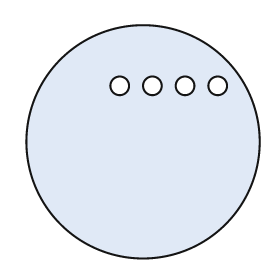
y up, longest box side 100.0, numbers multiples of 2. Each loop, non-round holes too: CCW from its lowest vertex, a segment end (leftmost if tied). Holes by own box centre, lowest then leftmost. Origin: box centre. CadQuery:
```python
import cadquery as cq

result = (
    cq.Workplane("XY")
    .moveTo(0.0, 0.0)
    .circle(50.0)
    .moveTo(-10.0, 24.0)
    .circle(4.0)
    .moveTo(4.0, 24.0)
    .circle(4.0)
    .moveTo(18.0, 24.0)
    .circle(4.0)
    .moveTo(32.0, 24.0)
    .circle(4.0)
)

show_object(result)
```